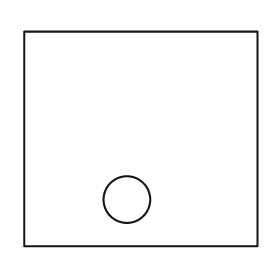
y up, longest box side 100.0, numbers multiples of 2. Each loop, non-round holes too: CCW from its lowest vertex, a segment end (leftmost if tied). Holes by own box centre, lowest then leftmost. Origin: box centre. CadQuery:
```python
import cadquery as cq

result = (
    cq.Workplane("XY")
    .moveTo(-50.0, -46.0)
    .lineTo(50.0, -46.0)
    .lineTo(50.0, 46.0)
    .lineTo(-50.0, 46.0)
    .close()
    .moveTo(-6.0, -26.0)
    .circle(10.0)
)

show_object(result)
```